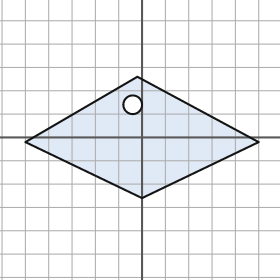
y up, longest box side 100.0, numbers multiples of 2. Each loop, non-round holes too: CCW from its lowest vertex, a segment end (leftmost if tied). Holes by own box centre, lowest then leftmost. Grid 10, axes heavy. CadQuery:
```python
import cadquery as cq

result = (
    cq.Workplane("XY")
    .moveTo(0.0, -26.0)
    .lineTo(50.0, -2.0)
    .lineTo(-2.0, 26.0)
    .lineTo(-50.0, -2.0)
    .close()
    .moveTo(-4.0, 14.0)
    .circle(4.0)
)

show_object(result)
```